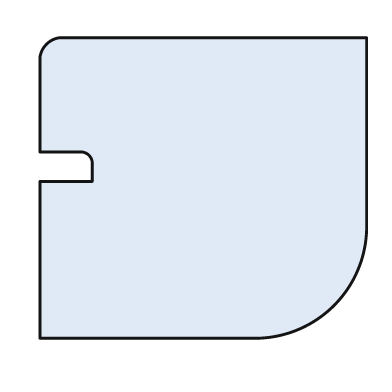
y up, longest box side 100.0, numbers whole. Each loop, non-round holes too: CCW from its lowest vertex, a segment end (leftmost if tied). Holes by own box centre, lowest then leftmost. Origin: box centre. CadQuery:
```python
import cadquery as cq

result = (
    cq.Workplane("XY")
    .moveTo(-50.0, -46.0)
    .lineTo(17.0, -46.0)
    .threePointArc((40.0, -36.0), (50.0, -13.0))
    .lineTo(50.0, 46.0)
    .lineTo(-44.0, 46.0)
    .threePointArc((-48.0, 44.0), (-50.0, 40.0))
    .lineTo(-50.0, 11.0)
    .lineTo(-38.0, 11.0)
    .threePointArc((-35.0, 10.0), (-34.0, 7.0))
    .lineTo(-34.0, 2.0)
    .lineTo(-50.0, 2.0)
    .close()
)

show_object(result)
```